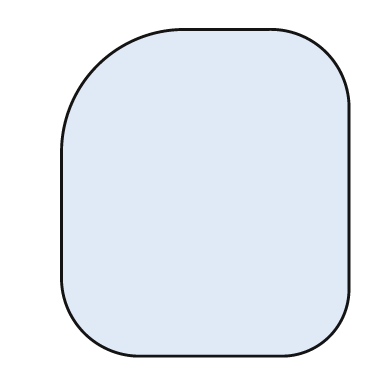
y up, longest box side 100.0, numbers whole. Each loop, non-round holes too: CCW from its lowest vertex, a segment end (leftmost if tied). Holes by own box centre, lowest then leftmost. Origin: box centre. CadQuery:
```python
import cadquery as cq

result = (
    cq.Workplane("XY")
    .moveTo(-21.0, -50.0)
    .lineTo(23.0, -50.0)
    .threePointArc((38.0, -44.0), (44.0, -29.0))
    .lineTo(44.0, 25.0)
    .threePointArc((37.0, 43.0), (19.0, 50.0))
    .lineTo(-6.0, 50.0)
    .threePointArc((-33.0, 39.0), (-44.0, 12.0))
    .lineTo(-44.0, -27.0)
    .threePointArc((-37.0, -43.0), (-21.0, -50.0))
    .close()
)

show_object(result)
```